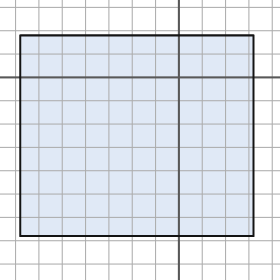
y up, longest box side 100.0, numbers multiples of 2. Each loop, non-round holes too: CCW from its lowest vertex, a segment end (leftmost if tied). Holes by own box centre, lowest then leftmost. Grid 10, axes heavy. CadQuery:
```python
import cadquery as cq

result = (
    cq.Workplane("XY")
    .moveTo(-68.0, -68.0)
    .lineTo(32.0, -68.0)
    .lineTo(32.0, 18.0)
    .lineTo(-68.0, 18.0)
    .close()
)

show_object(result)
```